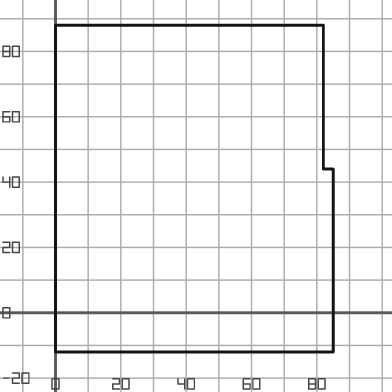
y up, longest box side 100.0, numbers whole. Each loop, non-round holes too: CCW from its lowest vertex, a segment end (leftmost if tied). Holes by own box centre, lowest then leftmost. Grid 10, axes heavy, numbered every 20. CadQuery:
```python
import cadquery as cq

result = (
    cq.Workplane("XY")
    .moveTo(0.0, -12.0)
    .lineTo(85.0, -12.0)
    .lineTo(85.0, 44.0)
    .lineTo(82.0, 44.0)
    .lineTo(82.0, 88.0)
    .lineTo(0.0, 88.0)
    .close()
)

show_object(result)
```